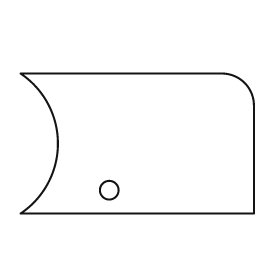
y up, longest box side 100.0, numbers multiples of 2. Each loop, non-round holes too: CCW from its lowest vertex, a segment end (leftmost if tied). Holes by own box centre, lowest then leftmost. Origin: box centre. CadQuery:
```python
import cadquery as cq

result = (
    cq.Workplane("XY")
    .moveTo(-50.0, -30.0)
    .lineTo(50.0, -30.0)
    .lineTo(50.0, 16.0)
    .threePointArc((46.0, 26.0), (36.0, 30.0))
    .lineTo(-50.0, 30.0)
    .threePointArc((-34.0, 0.0), (-50.0, -30.0))
    .close()
    .moveTo(-12.0, -20.0)
    .circle(4.0)
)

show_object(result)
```